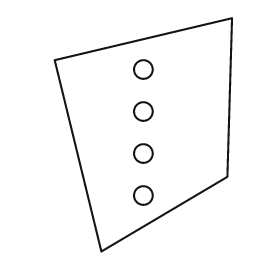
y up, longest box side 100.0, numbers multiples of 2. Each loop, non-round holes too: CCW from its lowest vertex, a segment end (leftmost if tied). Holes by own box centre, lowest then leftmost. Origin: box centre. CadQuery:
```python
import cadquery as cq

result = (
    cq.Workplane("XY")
    .moveTo(-18.0, -50.0)
    .lineTo(36.0, -18.0)
    .lineTo(38.0, 50.0)
    .lineTo(-38.0, 32.0)
    .close()
    .moveTo(0.0, -26.0)
    .circle(4.0)
    .moveTo(0.0, -8.0)
    .circle(4.0)
    .moveTo(0.0, 10.0)
    .circle(4.0)
    .moveTo(0.0, 28.0)
    .circle(4.0)
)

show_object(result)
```